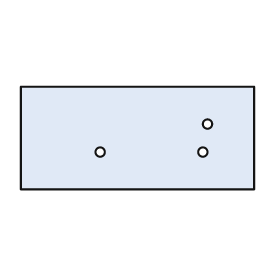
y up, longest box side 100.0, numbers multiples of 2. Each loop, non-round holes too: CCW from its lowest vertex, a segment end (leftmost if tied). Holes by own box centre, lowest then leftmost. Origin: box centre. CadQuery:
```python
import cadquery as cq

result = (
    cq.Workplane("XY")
    .moveTo(-50.0, -22.0)
    .lineTo(50.0, -22.0)
    .lineTo(50.0, 22.0)
    .lineTo(-50.0, 22.0)
    .close()
    .moveTo(-16.0, -6.0)
    .circle(2.0)
    .moveTo(28.0, -6.0)
    .circle(2.0)
    .moveTo(30.0, 6.0)
    .circle(2.0)
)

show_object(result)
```